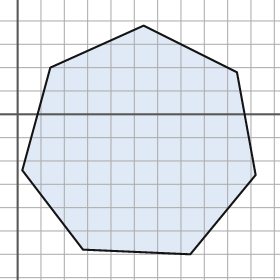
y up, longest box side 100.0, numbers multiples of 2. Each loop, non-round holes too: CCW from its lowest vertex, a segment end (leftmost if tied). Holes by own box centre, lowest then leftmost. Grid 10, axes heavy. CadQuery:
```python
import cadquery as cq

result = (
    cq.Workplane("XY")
    .moveTo(74.0, -60.0)
    .lineTo(102.0, -26.0)
    .lineTo(94.0, 18.0)
    .lineTo(54.0, 38.0)
    .lineTo(14.0, 20.0)
    .lineTo(2.0, -24.0)
    .lineTo(28.0, -58.0)
    .close()
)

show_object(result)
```